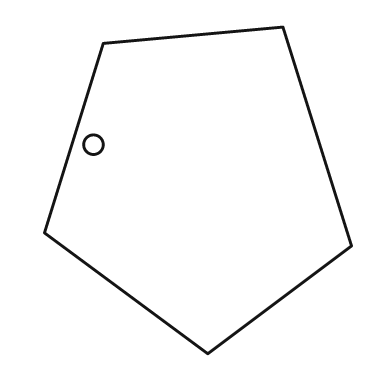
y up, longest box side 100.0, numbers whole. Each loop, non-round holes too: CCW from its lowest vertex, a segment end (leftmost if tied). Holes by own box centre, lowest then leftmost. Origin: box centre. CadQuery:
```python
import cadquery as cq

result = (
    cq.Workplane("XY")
    .moveTo(3.0, -50.0)
    .lineTo(47.0, -17.0)
    .lineTo(26.0, 50.0)
    .lineTo(-29.0, 45.0)
    .lineTo(-47.0, -13.0)
    .close()
    .moveTo(-32.0, 14.0)
    .circle(3.0)
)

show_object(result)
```